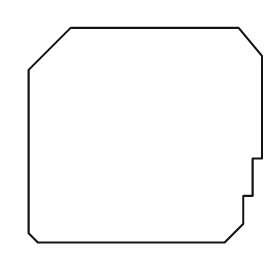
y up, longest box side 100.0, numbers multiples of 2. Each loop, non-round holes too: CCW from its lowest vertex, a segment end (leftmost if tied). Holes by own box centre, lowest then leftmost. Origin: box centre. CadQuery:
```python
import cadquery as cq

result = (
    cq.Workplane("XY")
    .moveTo(-46.0, -46.0)
    .lineTo(34.0, -46.0)
    .lineTo(42.0, -38.0)
    .lineTo(42.0, -26.0)
    .lineTo(46.0, -26.0)
    .lineTo(46.0, -10.0)
    .lineTo(50.0, -10.0)
    .lineTo(50.0, 34.0)
    .lineTo(40.0, 46.0)
    .lineTo(-32.0, 46.0)
    .lineTo(-50.0, 28.0)
    .lineTo(-50.0, -42.0)
    .close()
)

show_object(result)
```